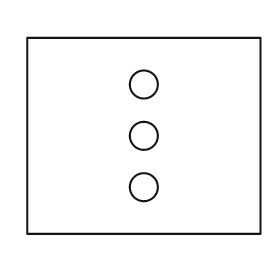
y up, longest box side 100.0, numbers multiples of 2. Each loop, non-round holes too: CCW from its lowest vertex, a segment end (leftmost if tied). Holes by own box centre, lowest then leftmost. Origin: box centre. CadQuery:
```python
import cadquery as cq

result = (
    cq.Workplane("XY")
    .moveTo(-50.0, -42.0)
    .lineTo(50.0, -42.0)
    .lineTo(50.0, 42.0)
    .lineTo(-50.0, 42.0)
    .close()
    .moveTo(0.0, -22.0)
    .circle(6.0)
    .moveTo(0.0, 0.0)
    .circle(6.0)
    .moveTo(0.0, 22.0)
    .circle(6.0)
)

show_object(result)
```